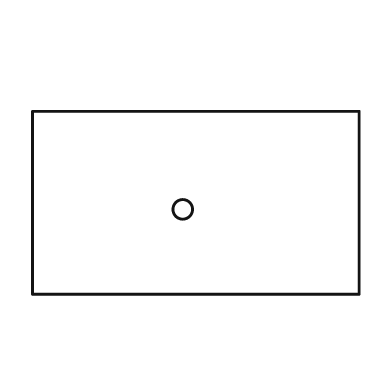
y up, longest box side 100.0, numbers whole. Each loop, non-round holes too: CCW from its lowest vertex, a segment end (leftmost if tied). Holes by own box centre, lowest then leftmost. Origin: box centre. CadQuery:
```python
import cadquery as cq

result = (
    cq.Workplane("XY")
    .moveTo(-50.0, -28.0)
    .lineTo(50.0, -28.0)
    .lineTo(50.0, 28.0)
    .lineTo(-50.0, 28.0)
    .close()
    .moveTo(-4.0, -2.0)
    .circle(3.0)
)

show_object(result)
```